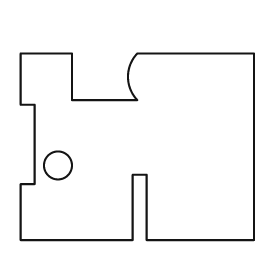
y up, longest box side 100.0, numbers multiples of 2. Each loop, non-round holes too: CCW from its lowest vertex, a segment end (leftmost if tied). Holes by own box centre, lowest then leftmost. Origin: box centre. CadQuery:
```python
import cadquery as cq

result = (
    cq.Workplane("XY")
    .moveTo(-50.0, -40.0)
    .lineTo(-2.0, -40.0)
    .lineTo(-2.0, -12.0)
    .lineTo(4.0, -12.0)
    .lineTo(4.0, -40.0)
    .lineTo(50.0, -40.0)
    .lineTo(50.0, 40.0)
    .lineTo(0.0, 40.0)
    .threePointArc((-4.0, 30.0), (0.0, 20.0))
    .lineTo(-28.0, 20.0)
    .lineTo(-28.0, 40.0)
    .lineTo(-50.0, 40.0)
    .lineTo(-50.0, 18.0)
    .lineTo(-44.0, 18.0)
    .lineTo(-44.0, -16.0)
    .lineTo(-50.0, -16.0)
    .close()
    .moveTo(-34.0, -8.0)
    .circle(6.0)
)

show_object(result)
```